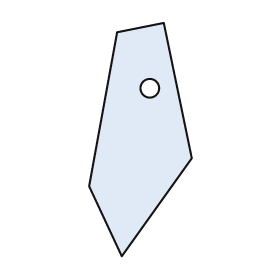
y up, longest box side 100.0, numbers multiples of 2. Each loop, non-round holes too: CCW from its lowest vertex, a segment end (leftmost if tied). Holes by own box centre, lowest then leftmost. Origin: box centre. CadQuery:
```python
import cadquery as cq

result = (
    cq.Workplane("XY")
    .moveTo(-8.0, -50.0)
    .lineTo(22.0, -8.0)
    .lineTo(10.0, 50.0)
    .lineTo(-10.0, 46.0)
    .lineTo(-22.0, -20.0)
    .close()
    .moveTo(4.0, 22.0)
    .circle(4.0)
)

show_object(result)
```